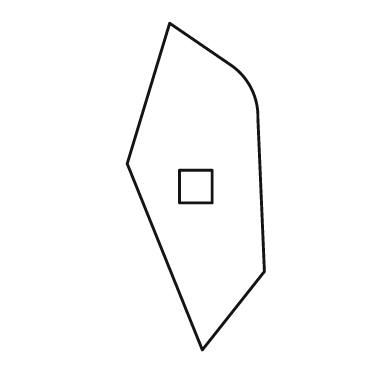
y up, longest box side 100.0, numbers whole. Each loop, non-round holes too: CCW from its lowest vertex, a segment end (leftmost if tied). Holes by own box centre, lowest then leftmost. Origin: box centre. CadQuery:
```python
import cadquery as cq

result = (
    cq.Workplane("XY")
    .moveTo(2.0, -50.0)
    .lineTo(21.0, -26.0)
    .lineTo(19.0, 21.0)
    .threePointArc((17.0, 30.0), (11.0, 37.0))
    .lineTo(-8.0, 50.0)
    .lineTo(-21.0, 7.0)
    .close()
    .moveTo(-5.0, -5.0)
    .lineTo(5.0, -5.0)
    .lineTo(5.0, 5.0)
    .lineTo(-5.0, 5.0)
    .close()
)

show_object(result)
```